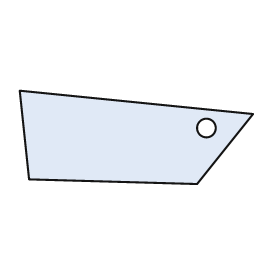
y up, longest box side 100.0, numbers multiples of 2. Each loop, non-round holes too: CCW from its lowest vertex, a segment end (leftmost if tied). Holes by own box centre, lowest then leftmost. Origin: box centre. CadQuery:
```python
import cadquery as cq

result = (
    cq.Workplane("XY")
    .moveTo(26.0, -20.0)
    .lineTo(50.0, 10.0)
    .lineTo(-50.0, 20.0)
    .lineTo(-46.0, -18.0)
    .close()
    .moveTo(30.0, 4.0)
    .circle(4.0)
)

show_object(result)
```